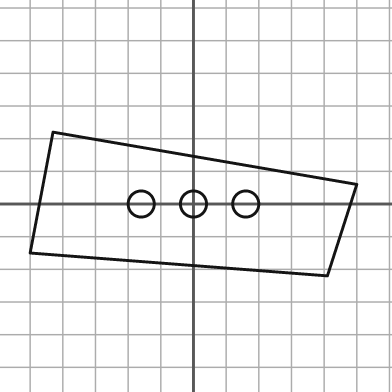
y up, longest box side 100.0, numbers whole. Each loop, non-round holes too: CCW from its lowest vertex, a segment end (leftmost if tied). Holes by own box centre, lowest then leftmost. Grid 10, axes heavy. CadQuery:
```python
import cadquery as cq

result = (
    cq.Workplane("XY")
    .moveTo(41.0, -22.0)
    .lineTo(50.0, 6.0)
    .lineTo(-43.0, 22.0)
    .lineTo(-50.0, -15.0)
    .close()
    .moveTo(-16.0, 0.0)
    .circle(4.0)
    .moveTo(0.0, 0.0)
    .circle(4.0)
    .moveTo(16.0, 0.0)
    .circle(4.0)
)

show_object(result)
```